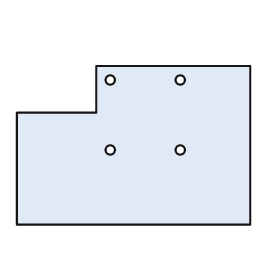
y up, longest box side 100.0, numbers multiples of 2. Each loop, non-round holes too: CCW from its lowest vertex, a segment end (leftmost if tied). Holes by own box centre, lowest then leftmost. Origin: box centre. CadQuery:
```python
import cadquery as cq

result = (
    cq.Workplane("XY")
    .moveTo(-50.0, -34.0)
    .lineTo(50.0, -34.0)
    .lineTo(50.0, 34.0)
    .lineTo(-16.0, 34.0)
    .lineTo(-16.0, 14.0)
    .lineTo(-50.0, 14.0)
    .close()
    .moveTo(-10.0, -2.0)
    .circle(2.0)
    .moveTo(20.0, -2.0)
    .circle(2.0)
    .moveTo(-10.0, 28.0)
    .circle(2.0)
    .moveTo(20.0, 28.0)
    .circle(2.0)
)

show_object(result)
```